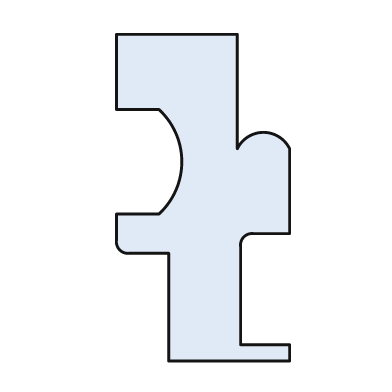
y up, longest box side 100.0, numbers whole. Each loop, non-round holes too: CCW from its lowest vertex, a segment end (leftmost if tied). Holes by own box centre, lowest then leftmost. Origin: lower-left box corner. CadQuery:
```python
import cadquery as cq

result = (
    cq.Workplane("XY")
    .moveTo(16.0, 0.0)
    .lineTo(53.0, 0.0)
    .lineTo(53.0, 5.0)
    .lineTo(38.0, 5.0)
    .lineTo(38.0, 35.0)
    .threePointArc((39.0, 38.0), (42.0, 39.0))
    .lineTo(53.0, 39.0)
    .lineTo(53.0, 65.0)
    .threePointArc((45.0, 70.0), (37.0, 65.0))
    .lineTo(37.0, 100.0)
    .lineTo(0.0, 100.0)
    .lineTo(0.0, 77.0)
    .lineTo(13.0, 77.0)
    .threePointArc((20.0, 61.0), (13.0, 45.0))
    .lineTo(0.0, 45.0)
    .lineTo(0.0, 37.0)
    .threePointArc((1.0, 34.0), (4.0, 33.0))
    .lineTo(16.0, 33.0)
    .close()
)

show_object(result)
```